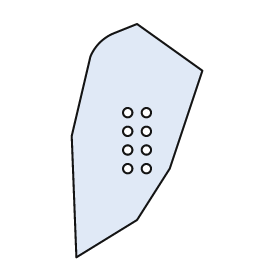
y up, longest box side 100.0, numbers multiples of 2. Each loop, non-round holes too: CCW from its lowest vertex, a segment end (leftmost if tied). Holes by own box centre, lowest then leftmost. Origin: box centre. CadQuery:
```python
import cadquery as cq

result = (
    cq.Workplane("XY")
    .moveTo(-26.0, -50.0)
    .lineTo(0.0, -34.0)
    .lineTo(14.0, -12.0)
    .lineTo(28.0, 30.0)
    .lineTo(0.0, 50.0)
    .lineTo(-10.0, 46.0)
    .threePointArc((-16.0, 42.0), (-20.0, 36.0))
    .lineTo(-28.0, 2.0)
    .close()
    .moveTo(-4.0, -12.0)
    .circle(2.0)
    .moveTo(4.0, -12.0)
    .circle(2.0)
    .moveTo(-4.0, -4.0)
    .circle(2.0)
    .moveTo(4.0, -4.0)
    .circle(2.0)
    .moveTo(-4.0, 4.0)
    .circle(2.0)
    .moveTo(4.0, 4.0)
    .circle(2.0)
    .moveTo(-4.0, 12.0)
    .circle(2.0)
    .moveTo(4.0, 12.0)
    .circle(2.0)
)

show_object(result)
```